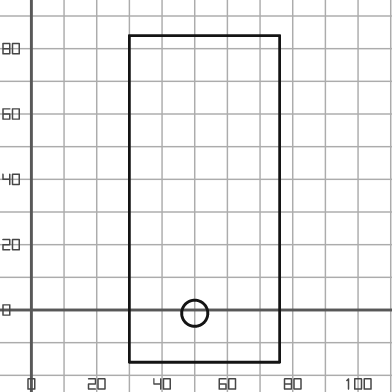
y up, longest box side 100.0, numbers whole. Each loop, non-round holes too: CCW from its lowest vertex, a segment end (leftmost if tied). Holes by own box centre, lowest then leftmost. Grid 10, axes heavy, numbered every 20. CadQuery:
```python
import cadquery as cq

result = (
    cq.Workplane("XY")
    .moveTo(30.0, -16.0)
    .lineTo(76.0, -16.0)
    .lineTo(76.0, 84.0)
    .lineTo(30.0, 84.0)
    .close()
    .moveTo(50.0, -1.0)
    .circle(4.0)
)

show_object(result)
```